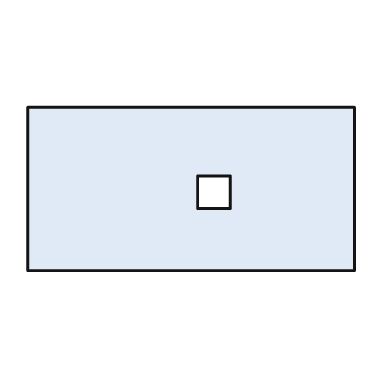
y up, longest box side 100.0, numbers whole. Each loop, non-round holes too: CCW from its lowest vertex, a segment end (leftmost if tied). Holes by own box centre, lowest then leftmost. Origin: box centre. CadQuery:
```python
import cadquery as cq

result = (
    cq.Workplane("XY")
    .moveTo(-50.0, -25.0)
    .lineTo(50.0, -25.0)
    .lineTo(50.0, 25.0)
    .lineTo(-50.0, 25.0)
    .close()
    .moveTo(2.0, -6.0)
    .lineTo(12.0, -6.0)
    .lineTo(12.0, 4.0)
    .lineTo(2.0, 4.0)
    .close()
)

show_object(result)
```